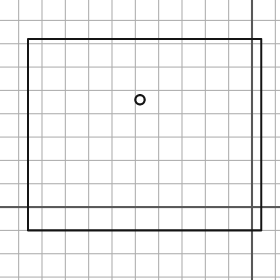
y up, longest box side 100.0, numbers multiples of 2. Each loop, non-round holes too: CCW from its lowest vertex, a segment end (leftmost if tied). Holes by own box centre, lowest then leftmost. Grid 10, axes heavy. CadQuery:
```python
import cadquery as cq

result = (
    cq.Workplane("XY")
    .moveTo(-96.0, -10.0)
    .lineTo(4.0, -10.0)
    .lineTo(4.0, 72.0)
    .lineTo(-96.0, 72.0)
    .close()
    .moveTo(-48.0, 46.0)
    .circle(2.0)
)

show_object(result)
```